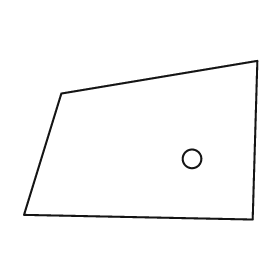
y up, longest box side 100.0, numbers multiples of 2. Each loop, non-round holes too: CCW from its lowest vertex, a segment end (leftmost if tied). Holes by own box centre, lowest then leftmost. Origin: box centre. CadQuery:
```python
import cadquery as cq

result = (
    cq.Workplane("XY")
    .moveTo(48.0, -34.0)
    .lineTo(50.0, 34.0)
    .lineTo(-34.0, 20.0)
    .lineTo(-50.0, -32.0)
    .close()
    .moveTo(22.0, -8.0)
    .circle(4.0)
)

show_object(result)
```